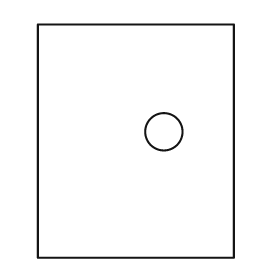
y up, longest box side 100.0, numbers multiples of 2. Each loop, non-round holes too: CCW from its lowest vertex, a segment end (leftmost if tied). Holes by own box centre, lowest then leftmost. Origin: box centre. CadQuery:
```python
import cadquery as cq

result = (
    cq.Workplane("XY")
    .moveTo(-42.0, -50.0)
    .lineTo(42.0, -50.0)
    .lineTo(42.0, 50.0)
    .lineTo(-42.0, 50.0)
    .close()
    .moveTo(12.0, 4.0)
    .circle(8.0)
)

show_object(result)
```